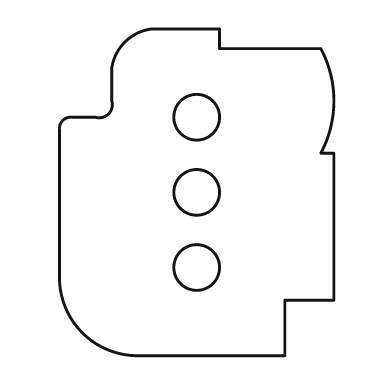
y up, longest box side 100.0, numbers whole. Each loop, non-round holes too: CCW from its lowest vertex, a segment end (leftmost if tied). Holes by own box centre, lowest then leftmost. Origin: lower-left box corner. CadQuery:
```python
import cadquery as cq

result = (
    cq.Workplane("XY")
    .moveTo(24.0, 0.0)
    .lineTo(69.0, 0.0)
    .lineTo(69.0, 17.0)
    .lineTo(84.0, 17.0)
    .lineTo(84.0, 62.0)
    .lineTo(80.0, 62.0)
    .threePointArc((84.0, 78.0), (80.0, 94.0))
    .lineTo(49.0, 94.0)
    .lineTo(49.0, 100.0)
    .lineTo(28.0, 100.0)
    .threePointArc((20.0, 96.0), (16.0, 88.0))
    .lineTo(16.0, 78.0)
    .threePointArc((15.0, 74.0), (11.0, 73.0))
    .lineTo(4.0, 73.0)
    .threePointArc((1.0, 72.0), (0.0, 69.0))
    .lineTo(0.0, 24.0)
    .threePointArc((7.0, 7.0), (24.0, 0.0))
    .close()
    .moveTo(42.0, 27.0)
    .circle(7.0)
    .moveTo(42.0, 50.0)
    .circle(7.0)
    .moveTo(42.0, 73.0)
    .circle(7.0)
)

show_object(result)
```